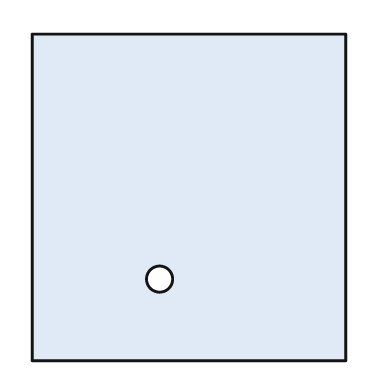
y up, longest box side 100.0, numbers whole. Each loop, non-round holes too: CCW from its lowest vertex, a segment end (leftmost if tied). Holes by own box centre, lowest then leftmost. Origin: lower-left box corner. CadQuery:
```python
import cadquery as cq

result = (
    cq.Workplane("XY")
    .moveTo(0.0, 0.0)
    .lineTo(96.0, 0.0)
    .lineTo(96.0, 100.0)
    .lineTo(0.0, 100.0)
    .close()
    .moveTo(39.0, 25.0)
    .circle(4.0)
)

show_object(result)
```